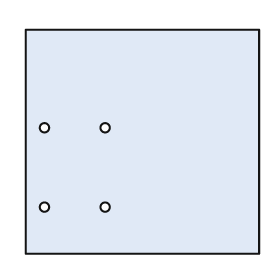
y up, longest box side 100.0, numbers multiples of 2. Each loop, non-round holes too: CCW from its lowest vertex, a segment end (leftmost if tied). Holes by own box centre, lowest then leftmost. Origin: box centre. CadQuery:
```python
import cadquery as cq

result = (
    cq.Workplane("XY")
    .moveTo(-50.0, -48.0)
    .lineTo(50.0, -48.0)
    .lineTo(50.0, 48.0)
    .lineTo(-50.0, 48.0)
    .close()
    .moveTo(-42.0, -28.0)
    .circle(2.0)
    .moveTo(-16.0, -28.0)
    .circle(2.0)
    .moveTo(-42.0, 6.0)
    .circle(2.0)
    .moveTo(-16.0, 6.0)
    .circle(2.0)
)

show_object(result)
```